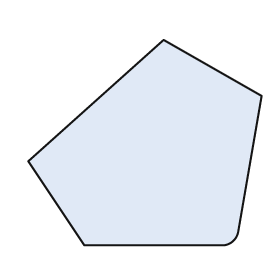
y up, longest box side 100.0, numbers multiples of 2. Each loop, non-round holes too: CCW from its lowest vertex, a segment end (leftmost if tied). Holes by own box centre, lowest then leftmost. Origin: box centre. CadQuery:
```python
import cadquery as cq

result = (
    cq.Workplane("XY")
    .moveTo(-26.0, -44.0)
    .lineTo(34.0, -44.0)
    .threePointArc((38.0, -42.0), (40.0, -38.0))
    .lineTo(50.0, 20.0)
    .lineTo(8.0, 44.0)
    .lineTo(-50.0, -8.0)
    .close()
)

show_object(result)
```